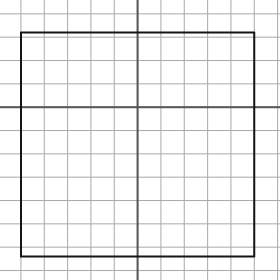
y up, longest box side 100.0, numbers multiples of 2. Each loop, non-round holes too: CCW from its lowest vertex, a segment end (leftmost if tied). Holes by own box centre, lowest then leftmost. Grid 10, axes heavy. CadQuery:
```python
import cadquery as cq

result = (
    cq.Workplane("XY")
    .moveTo(-50.0, -64.0)
    .lineTo(50.0, -64.0)
    .lineTo(50.0, 32.0)
    .lineTo(-50.0, 32.0)
    .close()
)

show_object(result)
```